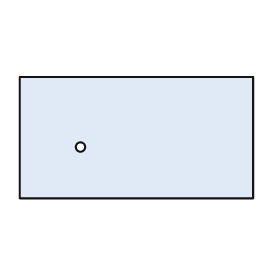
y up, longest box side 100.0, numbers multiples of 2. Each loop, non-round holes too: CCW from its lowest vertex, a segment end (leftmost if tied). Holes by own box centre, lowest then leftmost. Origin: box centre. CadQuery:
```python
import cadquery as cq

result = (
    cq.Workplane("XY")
    .moveTo(-50.0, -26.0)
    .lineTo(50.0, -26.0)
    .lineTo(50.0, 26.0)
    .lineTo(-50.0, 26.0)
    .close()
    .moveTo(-24.0, -4.0)
    .circle(2.0)
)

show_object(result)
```